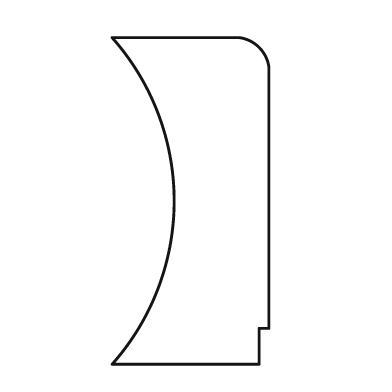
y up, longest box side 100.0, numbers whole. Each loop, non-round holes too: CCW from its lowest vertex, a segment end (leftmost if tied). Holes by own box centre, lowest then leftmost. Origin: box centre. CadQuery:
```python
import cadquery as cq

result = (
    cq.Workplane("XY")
    .moveTo(-24.0, -50.0)
    .lineTo(21.0, -50.0)
    .lineTo(21.0, -39.0)
    .lineTo(24.0, -39.0)
    .lineTo(24.0, 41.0)
    .threePointArc((21.0, 47.0), (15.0, 50.0))
    .lineTo(-24.0, 50.0)
    .threePointArc((-5.0, 0.0), (-24.0, -50.0))
    .close()
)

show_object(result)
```